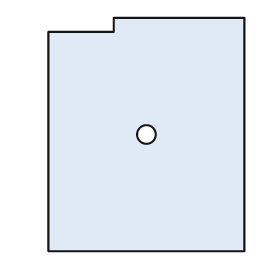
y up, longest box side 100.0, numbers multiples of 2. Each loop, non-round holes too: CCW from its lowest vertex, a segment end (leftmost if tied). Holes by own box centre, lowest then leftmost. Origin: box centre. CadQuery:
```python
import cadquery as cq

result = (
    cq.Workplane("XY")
    .moveTo(-42.0, -50.0)
    .lineTo(42.0, -50.0)
    .lineTo(42.0, 50.0)
    .lineTo(-14.0, 50.0)
    .lineTo(-14.0, 44.0)
    .lineTo(-42.0, 44.0)
    .close()
    .moveTo(0.0, 0.0)
    .circle(4.0)
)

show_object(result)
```